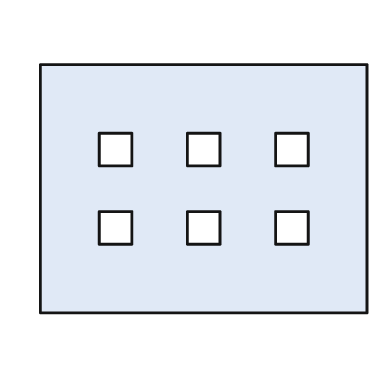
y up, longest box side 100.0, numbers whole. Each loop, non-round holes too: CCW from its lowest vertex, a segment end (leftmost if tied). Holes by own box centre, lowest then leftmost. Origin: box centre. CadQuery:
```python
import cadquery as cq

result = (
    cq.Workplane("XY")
    .moveTo(-50.0, -38.0)
    .lineTo(50.0, -38.0)
    .lineTo(50.0, 38.0)
    .lineTo(-50.0, 38.0)
    .close()
    .moveTo(-32.0, -17.0)
    .lineTo(-22.0, -17.0)
    .lineTo(-22.0, -7.0)
    .lineTo(-32.0, -7.0)
    .close()
    .moveTo(-5.0, -17.0)
    .lineTo(5.0, -17.0)
    .lineTo(5.0, -7.0)
    .lineTo(-5.0, -7.0)
    .close()
    .moveTo(22.0, -17.0)
    .lineTo(32.0, -17.0)
    .lineTo(32.0, -7.0)
    .lineTo(22.0, -7.0)
    .close()
    .moveTo(-32.0, 7.0)
    .lineTo(-22.0, 7.0)
    .lineTo(-22.0, 17.0)
    .lineTo(-32.0, 17.0)
    .close()
    .moveTo(-5.0, 7.0)
    .lineTo(5.0, 7.0)
    .lineTo(5.0, 17.0)
    .lineTo(-5.0, 17.0)
    .close()
    .moveTo(22.0, 7.0)
    .lineTo(32.0, 7.0)
    .lineTo(32.0, 17.0)
    .lineTo(22.0, 17.0)
    .close()
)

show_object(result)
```